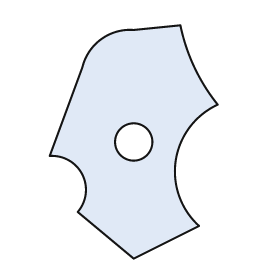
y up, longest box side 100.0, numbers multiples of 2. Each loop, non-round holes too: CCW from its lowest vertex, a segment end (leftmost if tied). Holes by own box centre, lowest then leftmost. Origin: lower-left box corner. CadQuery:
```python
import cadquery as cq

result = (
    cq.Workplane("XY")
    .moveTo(36.0, 0.0)
    .lineTo(64.0, 14.0)
    .threePointArc((54.0, 42.0), (72.0, 66.0))
    .threePointArc((62.0, 82.0), (56.0, 100.0))
    .lineTo(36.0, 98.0)
    .threePointArc((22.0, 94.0), (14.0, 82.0))
    .lineTo(0.0, 44.0)
    .threePointArc((14.0, 36.0), (12.0, 20.0))
    .close()
    .moveTo(36.0, 50.0)
    .circle(8.0)
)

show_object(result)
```